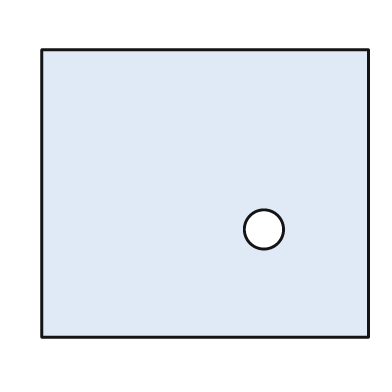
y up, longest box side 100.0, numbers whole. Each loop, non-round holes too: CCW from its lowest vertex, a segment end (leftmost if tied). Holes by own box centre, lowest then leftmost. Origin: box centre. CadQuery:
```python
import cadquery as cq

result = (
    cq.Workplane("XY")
    .moveTo(-50.0, -44.0)
    .lineTo(50.0, -44.0)
    .lineTo(50.0, 44.0)
    .lineTo(-50.0, 44.0)
    .close()
    .moveTo(18.0, -11.0)
    .circle(6.0)
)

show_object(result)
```